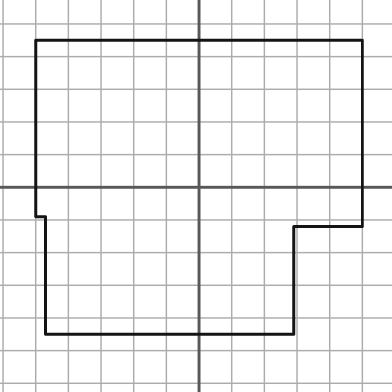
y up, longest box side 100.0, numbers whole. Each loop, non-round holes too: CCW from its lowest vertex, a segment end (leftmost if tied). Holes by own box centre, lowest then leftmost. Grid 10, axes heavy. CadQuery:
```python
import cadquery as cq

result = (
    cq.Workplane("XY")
    .moveTo(-47.0, -45.0)
    .lineTo(29.0, -45.0)
    .lineTo(29.0, -12.0)
    .lineTo(50.0, -12.0)
    .lineTo(50.0, 45.0)
    .lineTo(-50.0, 45.0)
    .lineTo(-50.0, -9.0)
    .lineTo(-47.0, -9.0)
    .close()
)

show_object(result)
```